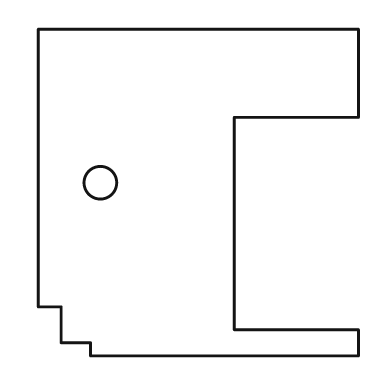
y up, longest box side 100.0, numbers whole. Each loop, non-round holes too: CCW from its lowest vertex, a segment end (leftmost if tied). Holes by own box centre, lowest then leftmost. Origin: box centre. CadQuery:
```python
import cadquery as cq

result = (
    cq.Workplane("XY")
    .moveTo(-33.0, -50.0)
    .lineTo(49.0, -50.0)
    .lineTo(49.0, -42.0)
    .lineTo(11.0, -42.0)
    .lineTo(11.0, 23.0)
    .lineTo(49.0, 23.0)
    .lineTo(49.0, 50.0)
    .lineTo(-49.0, 50.0)
    .lineTo(-49.0, -35.0)
    .lineTo(-42.0, -35.0)
    .lineTo(-42.0, -46.0)
    .lineTo(-33.0, -46.0)
    .close()
    .moveTo(-30.0, 3.0)
    .circle(5.0)
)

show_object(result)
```